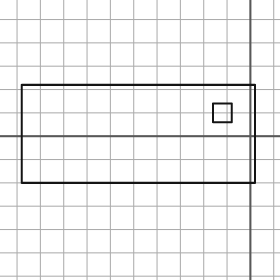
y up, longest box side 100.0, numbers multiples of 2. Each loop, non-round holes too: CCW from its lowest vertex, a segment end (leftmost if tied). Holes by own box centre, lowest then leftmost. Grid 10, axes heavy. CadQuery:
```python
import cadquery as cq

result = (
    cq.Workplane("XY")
    .moveTo(-98.0, -20.0)
    .lineTo(2.0, -20.0)
    .lineTo(2.0, 22.0)
    .lineTo(-98.0, 22.0)
    .close()
    .moveTo(-16.0, 6.0)
    .lineTo(-8.0, 6.0)
    .lineTo(-8.0, 14.0)
    .lineTo(-16.0, 14.0)
    .close()
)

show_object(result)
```